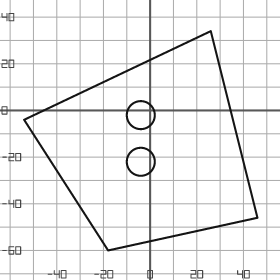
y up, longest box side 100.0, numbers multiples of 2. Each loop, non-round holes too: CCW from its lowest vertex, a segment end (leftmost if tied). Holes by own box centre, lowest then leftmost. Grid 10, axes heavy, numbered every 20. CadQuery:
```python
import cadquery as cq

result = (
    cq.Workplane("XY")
    .moveTo(-18.0, -60.0)
    .lineTo(46.0, -46.0)
    .lineTo(26.0, 34.0)
    .lineTo(-54.0, -4.0)
    .close()
    .moveTo(-4.0, -22.0)
    .circle(6.0)
    .moveTo(-4.0, -2.0)
    .circle(6.0)
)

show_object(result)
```